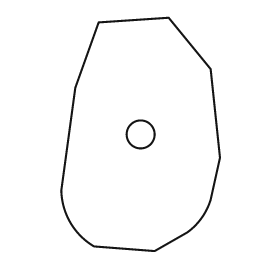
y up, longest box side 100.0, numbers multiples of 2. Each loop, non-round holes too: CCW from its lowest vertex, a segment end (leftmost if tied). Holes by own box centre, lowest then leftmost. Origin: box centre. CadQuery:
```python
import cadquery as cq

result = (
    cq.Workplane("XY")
    .moveTo(6.0, -50.0)
    .lineTo(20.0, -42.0)
    .threePointArc((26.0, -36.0), (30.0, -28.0))
    .lineTo(34.0, -10.0)
    .lineTo(30.0, 28.0)
    .lineTo(12.0, 50.0)
    .lineTo(-18.0, 48.0)
    .lineTo(-28.0, 20.0)
    .lineTo(-34.0, -24.0)
    .threePointArc((-30.0, -38.0), (-20.0, -48.0))
    .close()
    .moveTo(0.0, 0.0)
    .circle(6.0)
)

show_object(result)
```